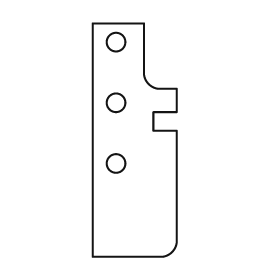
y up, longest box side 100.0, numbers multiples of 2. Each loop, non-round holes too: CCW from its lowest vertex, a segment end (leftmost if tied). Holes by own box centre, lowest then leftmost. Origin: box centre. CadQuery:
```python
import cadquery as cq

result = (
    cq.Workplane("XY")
    .moveTo(-18.0, -50.0)
    .lineTo(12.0, -50.0)
    .threePointArc((16.0, -48.0), (18.0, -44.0))
    .lineTo(18.0, 4.0)
    .lineTo(8.0, 4.0)
    .lineTo(8.0, 12.0)
    .lineTo(18.0, 12.0)
    .lineTo(18.0, 22.0)
    .lineTo(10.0, 22.0)
    .threePointArc((6.0, 24.0), (4.0, 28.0))
    .lineTo(4.0, 50.0)
    .lineTo(-18.0, 50.0)
    .close()
    .moveTo(-8.0, -10.0)
    .circle(4.0)
    .moveTo(-8.0, 16.0)
    .circle(4.0)
    .moveTo(-8.0, 42.0)
    .circle(4.0)
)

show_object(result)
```